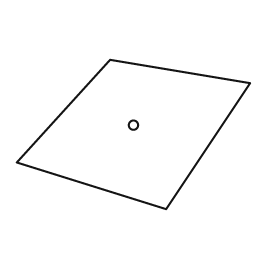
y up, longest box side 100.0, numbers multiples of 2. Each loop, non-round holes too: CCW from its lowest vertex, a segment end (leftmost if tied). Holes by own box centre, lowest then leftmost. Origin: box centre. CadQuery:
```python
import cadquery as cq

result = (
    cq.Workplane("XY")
    .moveTo(14.0, -32.0)
    .lineTo(50.0, 22.0)
    .lineTo(-10.0, 32.0)
    .lineTo(-50.0, -12.0)
    .close()
    .moveTo(0.0, 4.0)
    .circle(2.0)
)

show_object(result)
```